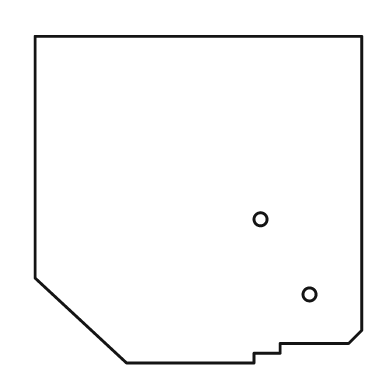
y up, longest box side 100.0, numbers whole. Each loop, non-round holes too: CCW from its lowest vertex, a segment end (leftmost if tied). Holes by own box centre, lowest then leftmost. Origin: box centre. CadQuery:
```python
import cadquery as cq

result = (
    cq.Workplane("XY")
    .moveTo(-22.0, -50.0)
    .lineTo(17.0, -50.0)
    .lineTo(17.0, -47.0)
    .lineTo(25.0, -47.0)
    .lineTo(25.0, -44.0)
    .lineTo(46.0, -44.0)
    .lineTo(50.0, -40.0)
    .lineTo(50.0, 50.0)
    .lineTo(-50.0, 50.0)
    .lineTo(-50.0, -24.0)
    .close()
    .moveTo(34.0, -29.0)
    .circle(2.0)
    .moveTo(19.0, -6.0)
    .circle(2.0)
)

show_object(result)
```